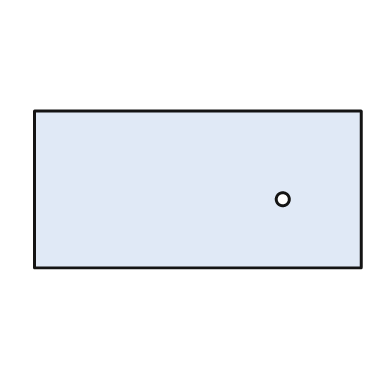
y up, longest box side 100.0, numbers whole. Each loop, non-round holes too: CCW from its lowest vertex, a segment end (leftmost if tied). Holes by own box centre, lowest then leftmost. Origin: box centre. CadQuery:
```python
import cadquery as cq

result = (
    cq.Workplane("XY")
    .moveTo(-50.0, -24.0)
    .lineTo(50.0, -24.0)
    .lineTo(50.0, 24.0)
    .lineTo(-50.0, 24.0)
    .close()
    .moveTo(26.0, -3.0)
    .circle(2.0)
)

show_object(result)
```